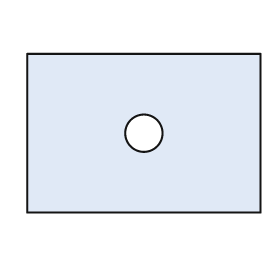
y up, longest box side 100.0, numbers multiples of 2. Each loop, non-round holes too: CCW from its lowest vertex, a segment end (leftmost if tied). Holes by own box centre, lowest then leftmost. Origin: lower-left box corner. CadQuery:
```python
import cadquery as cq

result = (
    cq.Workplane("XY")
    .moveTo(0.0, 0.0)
    .lineTo(100.0, 0.0)
    .lineTo(100.0, 68.0)
    .lineTo(0.0, 68.0)
    .close()
    .moveTo(50.0, 34.0)
    .circle(8.0)
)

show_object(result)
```